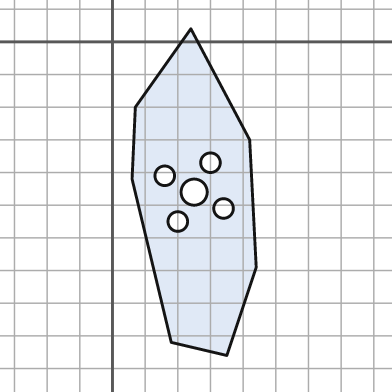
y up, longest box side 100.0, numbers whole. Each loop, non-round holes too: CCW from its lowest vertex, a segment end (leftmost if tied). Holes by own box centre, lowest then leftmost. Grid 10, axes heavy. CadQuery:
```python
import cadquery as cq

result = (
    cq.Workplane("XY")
    .moveTo(35.0, -96.0)
    .lineTo(44.0, -69.0)
    .lineTo(42.0, -30.0)
    .lineTo(24.0, 4.0)
    .lineTo(7.0, -20.0)
    .lineTo(6.0, -42.0)
    .lineTo(18.0, -92.0)
    .close()
    .moveTo(20.0, -55.0)
    .circle(3.0)
    .moveTo(34.0, -51.0)
    .circle(3.0)
    .moveTo(25.0, -46.0)
    .circle(4.0)
    .moveTo(16.0, -41.0)
    .circle(3.0)
    .moveTo(30.0, -37.0)
    .circle(3.0)
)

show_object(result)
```